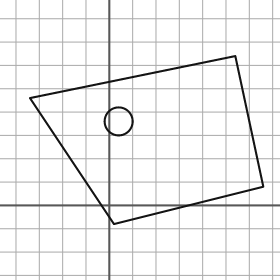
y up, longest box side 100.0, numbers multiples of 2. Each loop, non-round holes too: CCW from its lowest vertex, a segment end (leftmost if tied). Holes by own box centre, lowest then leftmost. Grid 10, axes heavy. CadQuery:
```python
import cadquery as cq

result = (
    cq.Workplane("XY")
    .moveTo(2.0, -8.0)
    .lineTo(66.0, 8.0)
    .lineTo(54.0, 64.0)
    .lineTo(-34.0, 46.0)
    .close()
    .moveTo(4.0, 36.0)
    .circle(6.0)
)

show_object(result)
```